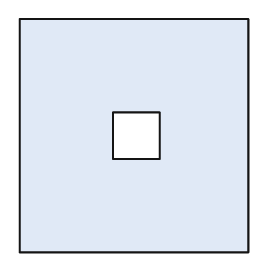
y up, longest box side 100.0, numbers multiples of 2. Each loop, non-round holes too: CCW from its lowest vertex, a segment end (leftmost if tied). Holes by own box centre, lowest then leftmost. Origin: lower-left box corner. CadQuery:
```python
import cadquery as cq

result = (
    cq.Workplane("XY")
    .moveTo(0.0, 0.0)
    .lineTo(98.0, 0.0)
    .lineTo(98.0, 100.0)
    .lineTo(0.0, 100.0)
    .close()
    .moveTo(40.0, 40.0)
    .lineTo(60.0, 40.0)
    .lineTo(60.0, 60.0)
    .lineTo(40.0, 60.0)
    .close()
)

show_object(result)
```